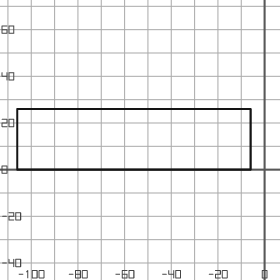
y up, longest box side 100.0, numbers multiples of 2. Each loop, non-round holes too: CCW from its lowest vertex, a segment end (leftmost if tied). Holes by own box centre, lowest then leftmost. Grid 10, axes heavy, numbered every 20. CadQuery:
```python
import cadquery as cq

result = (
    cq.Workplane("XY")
    .moveTo(-106.0, 0.0)
    .lineTo(-6.0, 0.0)
    .lineTo(-6.0, 26.0)
    .lineTo(-106.0, 26.0)
    .close()
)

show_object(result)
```